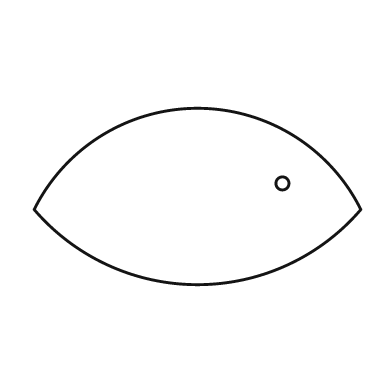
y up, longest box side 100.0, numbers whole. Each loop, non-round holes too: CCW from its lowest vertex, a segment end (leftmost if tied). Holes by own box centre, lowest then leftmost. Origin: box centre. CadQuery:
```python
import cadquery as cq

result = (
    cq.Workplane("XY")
    .moveTo(-50.0, -4.0)
    .threePointArc((0.0, -27.0), (50.0, -4.0))
    .threePointArc((0.0, 27.0), (-50.0, -4.0))
    .close()
    .moveTo(26.0, 4.0)
    .circle(2.0)
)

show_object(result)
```